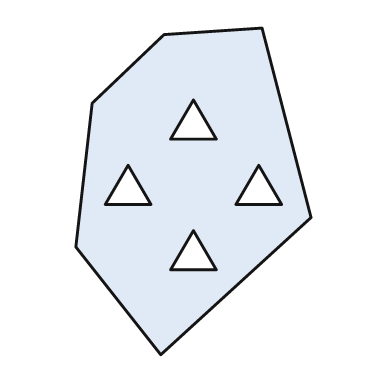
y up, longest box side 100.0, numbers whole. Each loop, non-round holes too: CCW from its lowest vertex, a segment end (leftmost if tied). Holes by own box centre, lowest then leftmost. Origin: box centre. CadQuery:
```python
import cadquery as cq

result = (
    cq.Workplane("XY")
    .moveTo(-10.0, -50.0)
    .lineTo(36.0, -8.0)
    .lineTo(21.0, 50.0)
    .lineTo(-9.0, 48.0)
    .lineTo(-31.0, 27.0)
    .lineTo(-36.0, -17.0)
    .close()
    .moveTo(-7.0, -24.0)
    .lineTo(7.0, -24.0)
    .lineTo(0.0, -12.0)
    .close()
    .moveTo(-27.0, -4.0)
    .lineTo(-13.0, -4.0)
    .lineTo(-20.0, 8.0)
    .close()
    .moveTo(13.0, -4.0)
    .lineTo(27.0, -4.0)
    .lineTo(20.0, 8.0)
    .close()
    .moveTo(-7.0, 16.0)
    .lineTo(7.0, 16.0)
    .lineTo(0.0, 28.0)
    .close()
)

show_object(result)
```